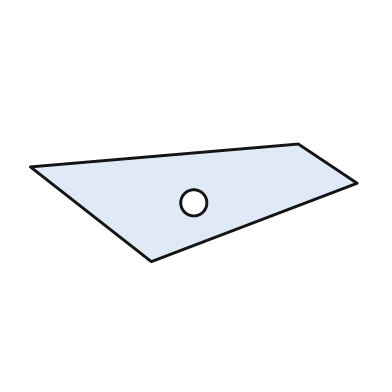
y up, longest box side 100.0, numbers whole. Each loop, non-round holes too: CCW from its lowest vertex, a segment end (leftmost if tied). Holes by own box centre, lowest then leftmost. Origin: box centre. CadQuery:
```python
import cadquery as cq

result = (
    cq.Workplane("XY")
    .moveTo(-13.0, -18.0)
    .lineTo(50.0, 6.0)
    .lineTo(32.0, 18.0)
    .lineTo(-50.0, 11.0)
    .close()
    .moveTo(0.0, 0.0)
    .circle(4.0)
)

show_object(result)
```